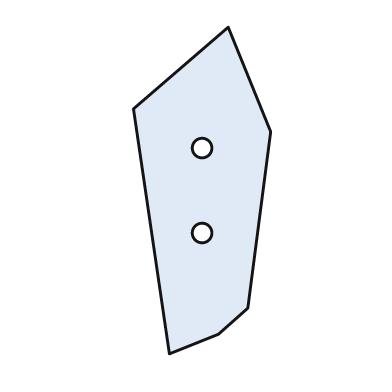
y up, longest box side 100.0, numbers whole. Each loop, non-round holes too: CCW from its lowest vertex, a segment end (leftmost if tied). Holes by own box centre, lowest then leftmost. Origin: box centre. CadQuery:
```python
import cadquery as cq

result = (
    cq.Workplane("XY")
    .moveTo(-10.0, -50.0)
    .lineTo(5.0, -44.0)
    .lineTo(14.0, -36.0)
    .lineTo(21.0, 18.0)
    .lineTo(8.0, 50.0)
    .lineTo(-21.0, 25.0)
    .close()
    .moveTo(0.0, -13.0)
    .circle(3.0)
    .moveTo(0.0, 13.0)
    .circle(3.0)
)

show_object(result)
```